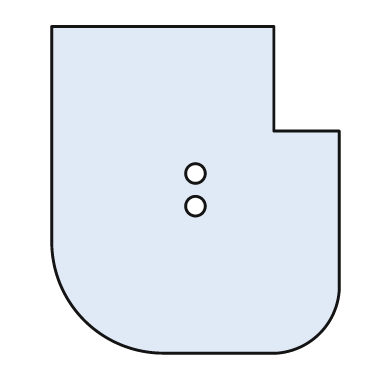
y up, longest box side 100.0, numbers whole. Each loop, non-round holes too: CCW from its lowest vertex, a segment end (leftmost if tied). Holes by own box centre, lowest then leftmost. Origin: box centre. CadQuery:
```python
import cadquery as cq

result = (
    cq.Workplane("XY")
    .moveTo(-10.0, -50.0)
    .lineTo(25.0, -50.0)
    .threePointArc((38.0, -44.0), (44.0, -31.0))
    .lineTo(44.0, 18.0)
    .lineTo(24.0, 18.0)
    .lineTo(24.0, 50.0)
    .lineTo(-44.0, 50.0)
    .lineTo(-44.0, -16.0)
    .threePointArc((-34.0, -40.0), (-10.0, -50.0))
    .close()
    .moveTo(0.0, -5.0)
    .circle(3.0)
    .moveTo(0.0, 5.0)
    .circle(3.0)
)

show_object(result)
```